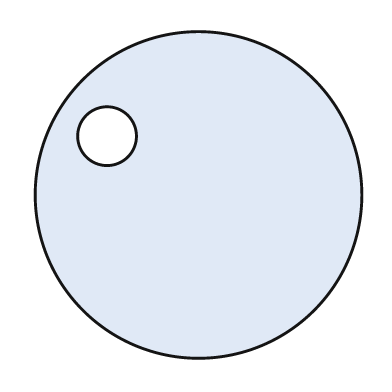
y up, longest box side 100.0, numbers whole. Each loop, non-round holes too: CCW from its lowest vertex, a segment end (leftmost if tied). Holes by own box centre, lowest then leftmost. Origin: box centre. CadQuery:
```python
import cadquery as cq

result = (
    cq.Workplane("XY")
    .moveTo(0.0, 0.0)
    .circle(50.0)
    .moveTo(-28.0, 18.0)
    .circle(9.0)
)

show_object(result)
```